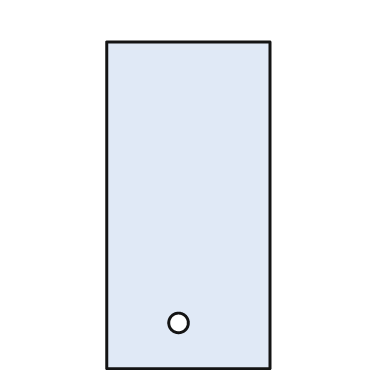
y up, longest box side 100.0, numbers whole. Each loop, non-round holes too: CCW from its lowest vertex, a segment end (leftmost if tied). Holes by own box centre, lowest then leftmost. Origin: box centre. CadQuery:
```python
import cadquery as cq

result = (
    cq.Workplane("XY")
    .moveTo(-25.0, -50.0)
    .lineTo(25.0, -50.0)
    .lineTo(25.0, 50.0)
    .lineTo(-25.0, 50.0)
    .close()
    .moveTo(-3.0, -36.0)
    .circle(3.0)
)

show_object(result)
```